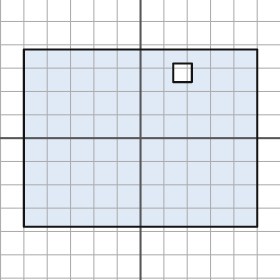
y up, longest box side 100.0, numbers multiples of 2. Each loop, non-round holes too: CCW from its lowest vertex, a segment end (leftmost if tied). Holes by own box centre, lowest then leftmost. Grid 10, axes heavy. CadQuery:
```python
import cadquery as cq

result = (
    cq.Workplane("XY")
    .moveTo(-50.0, -38.0)
    .lineTo(50.0, -38.0)
    .lineTo(50.0, 38.0)
    .lineTo(-50.0, 38.0)
    .close()
    .moveTo(14.0, 24.0)
    .lineTo(22.0, 24.0)
    .lineTo(22.0, 32.0)
    .lineTo(14.0, 32.0)
    .close()
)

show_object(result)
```